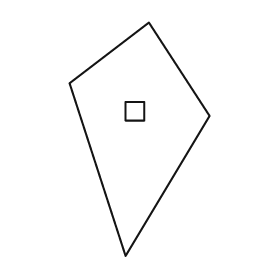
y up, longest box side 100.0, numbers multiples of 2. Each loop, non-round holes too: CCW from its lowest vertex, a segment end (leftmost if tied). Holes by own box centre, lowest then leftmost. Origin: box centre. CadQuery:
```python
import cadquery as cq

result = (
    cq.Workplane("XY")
    .moveTo(-6.0, -50.0)
    .lineTo(30.0, 10.0)
    .lineTo(4.0, 50.0)
    .lineTo(-30.0, 24.0)
    .close()
    .moveTo(-6.0, 8.0)
    .lineTo(2.0, 8.0)
    .lineTo(2.0, 16.0)
    .lineTo(-6.0, 16.0)
    .close()
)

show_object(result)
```